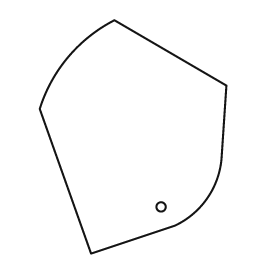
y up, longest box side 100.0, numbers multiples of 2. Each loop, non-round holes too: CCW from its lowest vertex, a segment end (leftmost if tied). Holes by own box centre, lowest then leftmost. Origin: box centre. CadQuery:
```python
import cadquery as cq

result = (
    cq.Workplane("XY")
    .moveTo(-18.0, -50.0)
    .lineTo(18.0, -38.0)
    .threePointArc((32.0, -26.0), (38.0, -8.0))
    .lineTo(40.0, 22.0)
    .lineTo(-8.0, 50.0)
    .threePointArc((-28.0, 34.0), (-40.0, 12.0))
    .close()
    .moveTo(12.0, -30.0)
    .circle(2.0)
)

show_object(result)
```